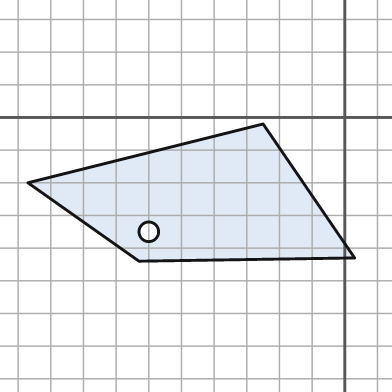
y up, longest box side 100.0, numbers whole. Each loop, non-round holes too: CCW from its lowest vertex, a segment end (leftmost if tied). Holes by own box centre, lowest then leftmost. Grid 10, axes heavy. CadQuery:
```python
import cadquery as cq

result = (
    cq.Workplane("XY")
    .moveTo(-63.0, -44.0)
    .lineTo(3.0, -43.0)
    .lineTo(-25.0, -2.0)
    .lineTo(-97.0, -20.0)
    .close()
    .moveTo(-60.0, -35.0)
    .circle(3.0)
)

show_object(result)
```